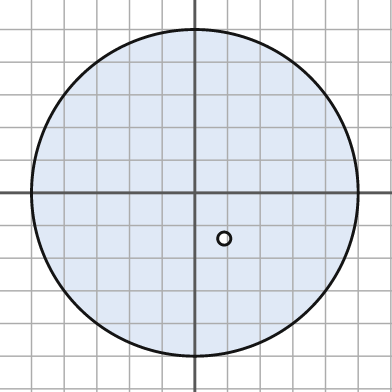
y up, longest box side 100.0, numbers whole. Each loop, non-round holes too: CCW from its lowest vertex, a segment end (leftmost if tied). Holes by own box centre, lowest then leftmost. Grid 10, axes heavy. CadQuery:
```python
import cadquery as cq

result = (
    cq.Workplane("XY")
    .moveTo(0.0, 0.0)
    .circle(50.0)
    .moveTo(9.0, -14.0)
    .circle(2.0)
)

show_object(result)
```